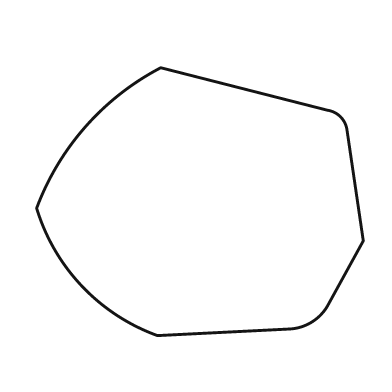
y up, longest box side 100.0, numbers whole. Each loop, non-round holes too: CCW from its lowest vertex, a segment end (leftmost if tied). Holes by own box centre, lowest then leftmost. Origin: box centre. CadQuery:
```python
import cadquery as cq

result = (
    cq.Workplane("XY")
    .moveTo(-13.0, -41.0)
    .lineTo(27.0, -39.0)
    .threePointArc((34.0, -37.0), (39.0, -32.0))
    .lineTo(50.0, -12.0)
    .lineTo(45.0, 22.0)
    .threePointArc((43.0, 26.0), (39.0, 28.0))
    .lineTo(-12.0, 41.0)
    .threePointArc((-35.0, 23.0), (-50.0, -2.0))
    .threePointArc((-36.0, -26.0), (-13.0, -41.0))
    .close()
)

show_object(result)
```